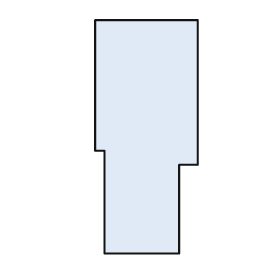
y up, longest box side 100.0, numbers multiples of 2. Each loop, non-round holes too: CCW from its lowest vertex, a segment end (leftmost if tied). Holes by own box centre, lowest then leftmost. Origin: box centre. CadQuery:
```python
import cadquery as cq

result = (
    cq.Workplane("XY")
    .moveTo(-18.0, -50.0)
    .lineTo(14.0, -50.0)
    .lineTo(14.0, -12.0)
    .lineTo(22.0, -12.0)
    .lineTo(22.0, 50.0)
    .lineTo(-22.0, 50.0)
    .lineTo(-22.0, -6.0)
    .lineTo(-18.0, -6.0)
    .close()
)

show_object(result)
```